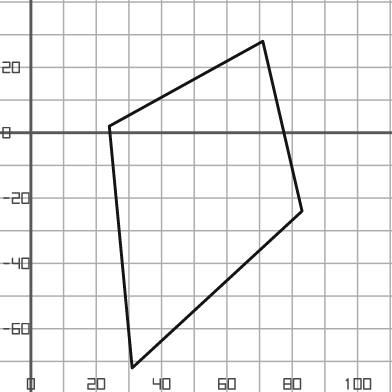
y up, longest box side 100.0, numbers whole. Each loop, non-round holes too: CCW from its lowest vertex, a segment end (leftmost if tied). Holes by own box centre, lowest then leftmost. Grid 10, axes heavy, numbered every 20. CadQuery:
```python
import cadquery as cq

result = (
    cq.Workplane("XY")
    .moveTo(31.0, -72.0)
    .lineTo(83.0, -24.0)
    .lineTo(71.0, 28.0)
    .lineTo(24.0, 2.0)
    .close()
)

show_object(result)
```